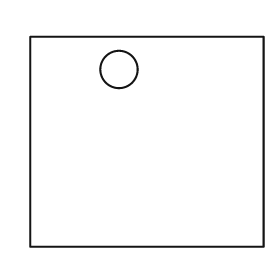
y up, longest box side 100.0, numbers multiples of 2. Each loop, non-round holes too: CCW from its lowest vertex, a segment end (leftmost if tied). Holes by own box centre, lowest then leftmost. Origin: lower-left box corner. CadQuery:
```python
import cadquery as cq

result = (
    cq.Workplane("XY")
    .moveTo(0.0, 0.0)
    .lineTo(100.0, 0.0)
    .lineTo(100.0, 90.0)
    .lineTo(0.0, 90.0)
    .close()
    .moveTo(38.0, 76.0)
    .circle(8.0)
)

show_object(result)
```